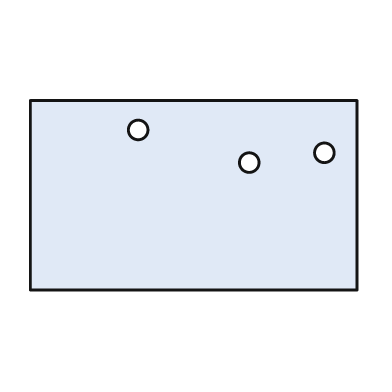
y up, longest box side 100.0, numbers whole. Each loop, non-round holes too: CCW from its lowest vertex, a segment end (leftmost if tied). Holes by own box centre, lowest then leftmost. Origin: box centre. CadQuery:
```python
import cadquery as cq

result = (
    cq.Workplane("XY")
    .moveTo(-50.0, -29.0)
    .lineTo(50.0, -29.0)
    .lineTo(50.0, 29.0)
    .lineTo(-50.0, 29.0)
    .close()
    .moveTo(17.0, 10.0)
    .circle(3.0)
    .moveTo(40.0, 13.0)
    .circle(3.0)
    .moveTo(-17.0, 20.0)
    .circle(3.0)
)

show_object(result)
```